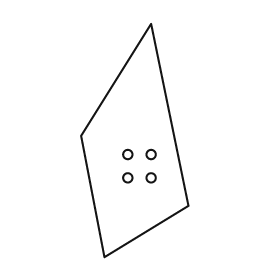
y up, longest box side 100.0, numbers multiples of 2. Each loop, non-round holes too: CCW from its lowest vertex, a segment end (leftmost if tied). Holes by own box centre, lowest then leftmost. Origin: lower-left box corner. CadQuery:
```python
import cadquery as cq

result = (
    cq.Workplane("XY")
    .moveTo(10.0, 0.0)
    .lineTo(46.0, 22.0)
    .lineTo(30.0, 100.0)
    .lineTo(0.0, 52.0)
    .close()
    .moveTo(20.0, 34.0)
    .circle(2.0)
    .moveTo(30.0, 34.0)
    .circle(2.0)
    .moveTo(20.0, 44.0)
    .circle(2.0)
    .moveTo(30.0, 44.0)
    .circle(2.0)
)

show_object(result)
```